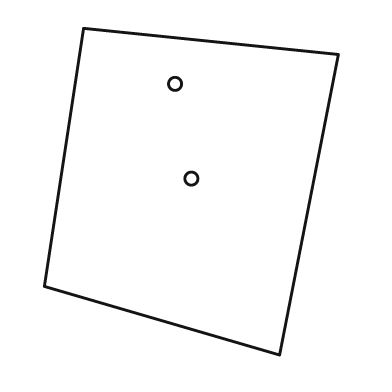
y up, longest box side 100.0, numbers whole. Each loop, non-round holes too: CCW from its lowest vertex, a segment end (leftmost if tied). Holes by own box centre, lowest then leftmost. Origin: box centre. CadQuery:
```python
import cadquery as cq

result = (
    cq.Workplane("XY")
    .moveTo(27.0, -50.0)
    .lineTo(45.0, 42.0)
    .lineTo(-33.0, 50.0)
    .lineTo(-45.0, -29.0)
    .close()
    .moveTo(0.0, 4.0)
    .circle(2.0)
    .moveTo(-5.0, 33.0)
    .circle(2.0)
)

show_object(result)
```